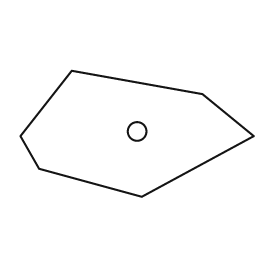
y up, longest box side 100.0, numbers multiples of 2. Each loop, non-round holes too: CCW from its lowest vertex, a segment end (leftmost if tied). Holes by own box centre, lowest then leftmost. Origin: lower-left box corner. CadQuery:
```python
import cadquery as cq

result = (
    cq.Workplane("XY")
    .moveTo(52.0, 0.0)
    .lineTo(100.0, 26.0)
    .lineTo(78.0, 44.0)
    .lineTo(22.0, 54.0)
    .lineTo(0.0, 26.0)
    .lineTo(8.0, 12.0)
    .close()
    .moveTo(50.0, 28.0)
    .circle(4.0)
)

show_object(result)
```